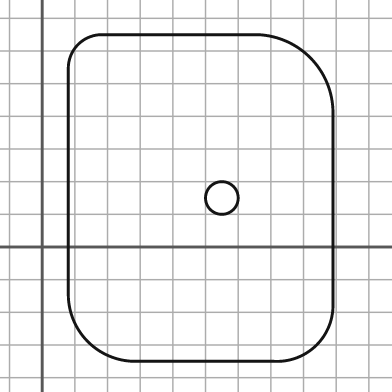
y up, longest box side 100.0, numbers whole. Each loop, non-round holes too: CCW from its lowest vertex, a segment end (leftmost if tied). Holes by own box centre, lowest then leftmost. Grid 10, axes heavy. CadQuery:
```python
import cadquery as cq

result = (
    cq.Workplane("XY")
    .moveTo(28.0, -35.0)
    .lineTo(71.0, -35.0)
    .threePointArc((84.0, -30.0), (89.0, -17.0))
    .lineTo(89.0, 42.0)
    .threePointArc((82.0, 58.0), (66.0, 65.0))
    .lineTo(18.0, 65.0)
    .threePointArc((11.0, 62.0), (8.0, 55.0))
    .lineTo(8.0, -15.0)
    .threePointArc((14.0, -29.0), (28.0, -35.0))
    .close()
    .moveTo(55.0, 15.0)
    .circle(5.0)
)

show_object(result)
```